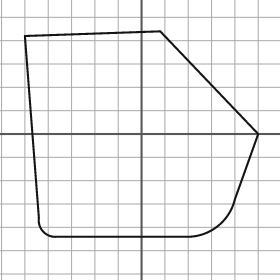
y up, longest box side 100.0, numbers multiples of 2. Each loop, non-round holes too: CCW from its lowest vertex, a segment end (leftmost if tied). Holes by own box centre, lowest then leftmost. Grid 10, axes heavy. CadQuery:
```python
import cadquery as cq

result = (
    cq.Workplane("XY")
    .moveTo(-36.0, -44.0)
    .lineTo(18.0, -44.0)
    .threePointArc((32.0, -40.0), (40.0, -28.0))
    .lineTo(50.0, 0.0)
    .lineTo(8.0, 44.0)
    .lineTo(-50.0, 42.0)
    .lineTo(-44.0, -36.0)
    .threePointArc((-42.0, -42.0), (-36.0, -44.0))
    .close()
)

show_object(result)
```